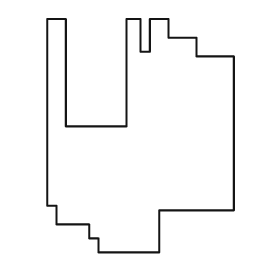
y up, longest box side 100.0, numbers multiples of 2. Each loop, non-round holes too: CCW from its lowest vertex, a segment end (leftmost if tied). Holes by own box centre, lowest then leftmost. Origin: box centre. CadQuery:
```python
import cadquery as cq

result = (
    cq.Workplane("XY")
    .moveTo(-18.0, -50.0)
    .lineTo(8.0, -50.0)
    .lineTo(8.0, -32.0)
    .lineTo(40.0, -32.0)
    .lineTo(40.0, 34.0)
    .lineTo(24.0, 34.0)
    .lineTo(24.0, 42.0)
    .lineTo(12.0, 42.0)
    .lineTo(12.0, 50.0)
    .lineTo(4.0, 50.0)
    .lineTo(4.0, 36.0)
    .lineTo(0.0, 36.0)
    .lineTo(0.0, 50.0)
    .lineTo(-6.0, 50.0)
    .lineTo(-6.0, 4.0)
    .lineTo(-32.0, 4.0)
    .lineTo(-32.0, 50.0)
    .lineTo(-40.0, 50.0)
    .lineTo(-40.0, -30.0)
    .lineTo(-36.0, -30.0)
    .lineTo(-36.0, -38.0)
    .lineTo(-22.0, -38.0)
    .lineTo(-22.0, -44.0)
    .lineTo(-18.0, -44.0)
    .close()
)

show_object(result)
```